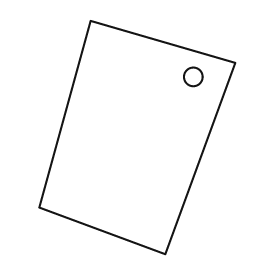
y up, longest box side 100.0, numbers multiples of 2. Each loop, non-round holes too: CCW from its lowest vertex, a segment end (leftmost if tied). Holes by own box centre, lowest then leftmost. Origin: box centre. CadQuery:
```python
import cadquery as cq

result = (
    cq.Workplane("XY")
    .moveTo(12.0, -50.0)
    .lineTo(42.0, 32.0)
    .lineTo(-20.0, 50.0)
    .lineTo(-42.0, -30.0)
    .close()
    .moveTo(24.0, 26.0)
    .circle(4.0)
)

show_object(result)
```